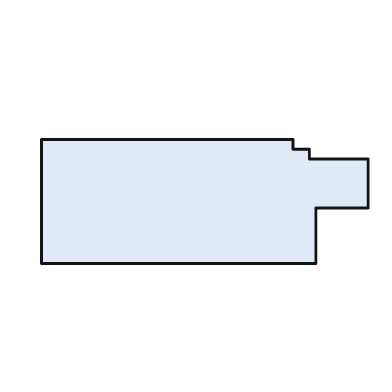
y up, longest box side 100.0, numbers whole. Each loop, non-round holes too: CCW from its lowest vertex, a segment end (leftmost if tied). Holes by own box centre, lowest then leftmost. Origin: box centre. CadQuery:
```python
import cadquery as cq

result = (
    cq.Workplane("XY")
    .moveTo(-50.0, -19.0)
    .lineTo(34.0, -19.0)
    .lineTo(34.0, -2.0)
    .lineTo(50.0, -2.0)
    .lineTo(50.0, 13.0)
    .lineTo(32.0, 13.0)
    .lineTo(32.0, 16.0)
    .lineTo(27.0, 16.0)
    .lineTo(27.0, 19.0)
    .lineTo(-50.0, 19.0)
    .close()
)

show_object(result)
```